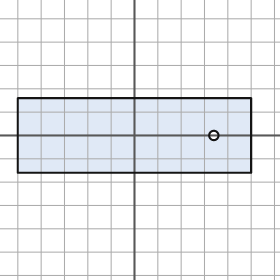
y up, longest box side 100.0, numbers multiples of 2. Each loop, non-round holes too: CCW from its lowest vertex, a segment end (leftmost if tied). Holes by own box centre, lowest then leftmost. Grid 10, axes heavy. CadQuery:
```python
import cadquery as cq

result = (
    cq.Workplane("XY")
    .moveTo(-50.0, -16.0)
    .lineTo(50.0, -16.0)
    .lineTo(50.0, 16.0)
    .lineTo(-50.0, 16.0)
    .close()
    .moveTo(34.0, 0.0)
    .circle(2.0)
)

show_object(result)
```